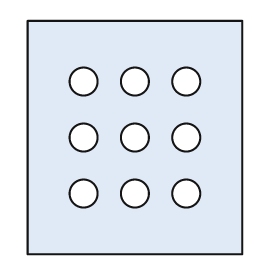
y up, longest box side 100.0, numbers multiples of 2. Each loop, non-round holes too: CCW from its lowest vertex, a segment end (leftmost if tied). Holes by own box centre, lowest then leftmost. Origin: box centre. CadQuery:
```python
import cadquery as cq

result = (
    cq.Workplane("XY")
    .moveTo(-46.0, -50.0)
    .lineTo(46.0, -50.0)
    .lineTo(46.0, 50.0)
    .lineTo(-46.0, 50.0)
    .close()
    .moveTo(-22.0, -24.0)
    .circle(6.0)
    .moveTo(0.0, -24.0)
    .circle(6.0)
    .moveTo(22.0, -24.0)
    .circle(6.0)
    .moveTo(-22.0, 0.0)
    .circle(6.0)
    .moveTo(0.0, 0.0)
    .circle(6.0)
    .moveTo(22.0, 0.0)
    .circle(6.0)
    .moveTo(-22.0, 24.0)
    .circle(6.0)
    .moveTo(0.0, 24.0)
    .circle(6.0)
    .moveTo(22.0, 24.0)
    .circle(6.0)
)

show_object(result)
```